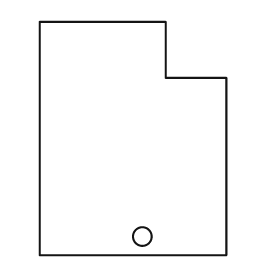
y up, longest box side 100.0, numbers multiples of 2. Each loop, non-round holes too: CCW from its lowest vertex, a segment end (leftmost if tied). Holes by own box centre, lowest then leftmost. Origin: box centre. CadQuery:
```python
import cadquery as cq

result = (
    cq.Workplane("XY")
    .moveTo(-40.0, -50.0)
    .lineTo(40.0, -50.0)
    .lineTo(40.0, 26.0)
    .lineTo(14.0, 26.0)
    .lineTo(14.0, 50.0)
    .lineTo(-40.0, 50.0)
    .close()
    .moveTo(4.0, -42.0)
    .circle(4.0)
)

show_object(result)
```